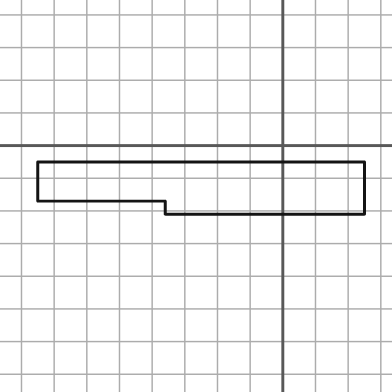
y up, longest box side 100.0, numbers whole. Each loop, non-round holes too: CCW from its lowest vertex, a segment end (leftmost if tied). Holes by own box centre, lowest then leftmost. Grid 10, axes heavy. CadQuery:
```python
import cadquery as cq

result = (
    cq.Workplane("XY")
    .moveTo(-36.0, -21.0)
    .lineTo(25.0, -21.0)
    .lineTo(25.0, -5.0)
    .lineTo(-75.0, -5.0)
    .lineTo(-75.0, -17.0)
    .lineTo(-36.0, -17.0)
    .close()
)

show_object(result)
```